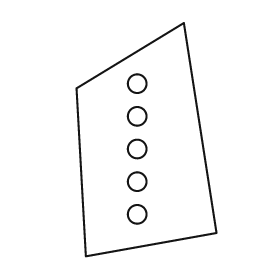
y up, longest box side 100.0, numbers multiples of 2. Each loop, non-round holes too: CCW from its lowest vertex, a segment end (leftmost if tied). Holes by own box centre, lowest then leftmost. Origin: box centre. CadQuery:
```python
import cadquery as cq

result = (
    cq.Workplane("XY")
    .moveTo(-26.0, -50.0)
    .lineTo(30.0, -40.0)
    .lineTo(16.0, 50.0)
    .lineTo(-30.0, 22.0)
    .close()
    .moveTo(-4.0, -32.0)
    .circle(4.0)
    .moveTo(-4.0, -18.0)
    .circle(4.0)
    .moveTo(-4.0, -4.0)
    .circle(4.0)
    .moveTo(-4.0, 10.0)
    .circle(4.0)
    .moveTo(-4.0, 24.0)
    .circle(4.0)
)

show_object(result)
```